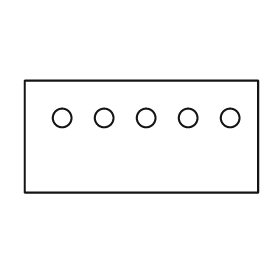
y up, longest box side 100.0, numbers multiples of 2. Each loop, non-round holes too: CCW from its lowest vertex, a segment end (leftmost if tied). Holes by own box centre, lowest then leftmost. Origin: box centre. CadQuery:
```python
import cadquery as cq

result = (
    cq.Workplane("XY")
    .moveTo(-50.0, -24.0)
    .lineTo(50.0, -24.0)
    .lineTo(50.0, 24.0)
    .lineTo(-50.0, 24.0)
    .close()
    .moveTo(-34.0, 8.0)
    .circle(4.0)
    .moveTo(-16.0, 8.0)
    .circle(4.0)
    .moveTo(2.0, 8.0)
    .circle(4.0)
    .moveTo(20.0, 8.0)
    .circle(4.0)
    .moveTo(38.0, 8.0)
    .circle(4.0)
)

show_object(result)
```